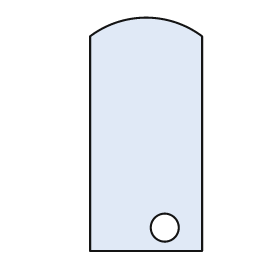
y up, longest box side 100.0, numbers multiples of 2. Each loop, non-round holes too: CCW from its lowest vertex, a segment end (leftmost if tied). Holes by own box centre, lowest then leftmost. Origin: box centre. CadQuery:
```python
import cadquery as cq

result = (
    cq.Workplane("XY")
    .moveTo(-24.0, -50.0)
    .lineTo(24.0, -50.0)
    .lineTo(24.0, 42.0)
    .threePointArc((0.0, 50.0), (-24.0, 42.0))
    .close()
    .moveTo(8.0, -40.0)
    .circle(6.0)
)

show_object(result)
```